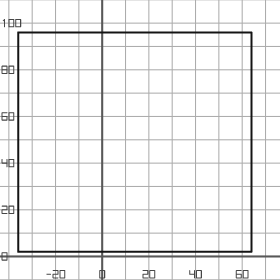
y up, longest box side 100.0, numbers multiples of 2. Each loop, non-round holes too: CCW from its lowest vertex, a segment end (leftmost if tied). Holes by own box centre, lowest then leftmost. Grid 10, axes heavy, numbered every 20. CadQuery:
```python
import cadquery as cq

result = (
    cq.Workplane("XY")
    .moveTo(-36.0, 2.0)
    .lineTo(64.0, 2.0)
    .lineTo(64.0, 96.0)
    .lineTo(-36.0, 96.0)
    .close()
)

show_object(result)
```